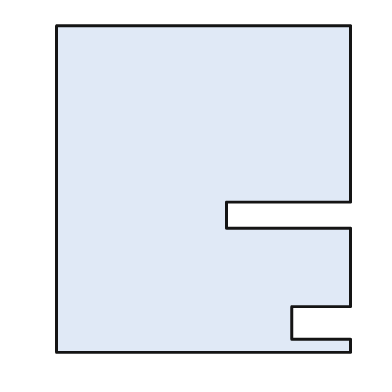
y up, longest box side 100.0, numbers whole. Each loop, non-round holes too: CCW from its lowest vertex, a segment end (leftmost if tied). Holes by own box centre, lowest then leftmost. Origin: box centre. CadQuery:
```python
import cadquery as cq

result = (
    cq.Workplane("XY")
    .moveTo(-45.0, -50.0)
    .lineTo(45.0, -50.0)
    .lineTo(45.0, -46.0)
    .lineTo(27.0, -46.0)
    .lineTo(27.0, -36.0)
    .lineTo(45.0, -36.0)
    .lineTo(45.0, -12.0)
    .lineTo(7.0, -12.0)
    .lineTo(7.0, -4.0)
    .lineTo(45.0, -4.0)
    .lineTo(45.0, 50.0)
    .lineTo(-45.0, 50.0)
    .close()
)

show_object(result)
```